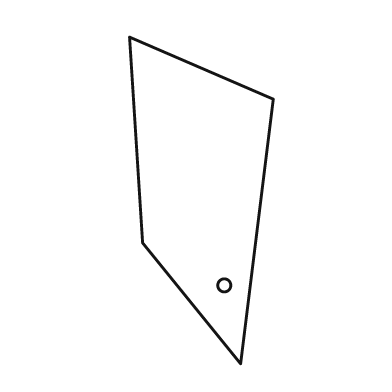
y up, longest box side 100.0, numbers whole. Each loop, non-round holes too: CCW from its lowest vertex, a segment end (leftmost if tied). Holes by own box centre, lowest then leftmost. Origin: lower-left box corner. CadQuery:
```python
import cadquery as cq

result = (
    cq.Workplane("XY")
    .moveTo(34.0, 0.0)
    .lineTo(44.0, 81.0)
    .lineTo(0.0, 100.0)
    .lineTo(4.0, 37.0)
    .close()
    .moveTo(29.0, 24.0)
    .circle(2.0)
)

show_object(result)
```